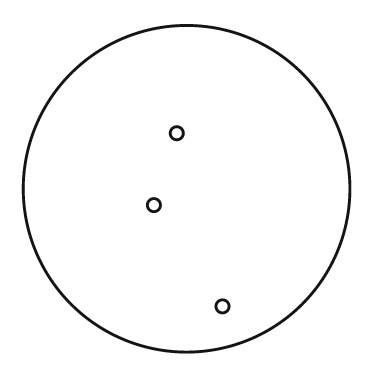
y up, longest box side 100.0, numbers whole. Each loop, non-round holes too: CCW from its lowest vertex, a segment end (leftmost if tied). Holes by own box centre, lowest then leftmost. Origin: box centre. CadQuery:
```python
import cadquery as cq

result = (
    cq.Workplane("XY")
    .moveTo(0.0, 0.0)
    .circle(50.0)
    .moveTo(11.0, -36.0)
    .circle(2.0)
    .moveTo(-10.0, -5.0)
    .circle(2.0)
    .moveTo(-3.0, 17.0)
    .circle(2.0)
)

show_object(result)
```